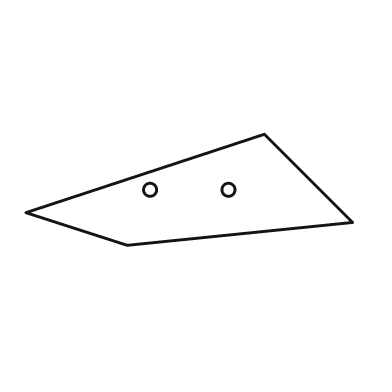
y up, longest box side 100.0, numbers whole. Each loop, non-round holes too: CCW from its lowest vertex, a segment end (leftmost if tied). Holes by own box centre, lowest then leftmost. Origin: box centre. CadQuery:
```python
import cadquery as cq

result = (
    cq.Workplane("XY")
    .moveTo(-19.0, -17.0)
    .lineTo(50.0, -10.0)
    .lineTo(23.0, 17.0)
    .lineTo(-50.0, -7.0)
    .close()
    .moveTo(-12.0, 0.0)
    .circle(2.0)
    .moveTo(12.0, 0.0)
    .circle(2.0)
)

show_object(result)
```